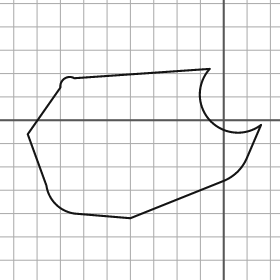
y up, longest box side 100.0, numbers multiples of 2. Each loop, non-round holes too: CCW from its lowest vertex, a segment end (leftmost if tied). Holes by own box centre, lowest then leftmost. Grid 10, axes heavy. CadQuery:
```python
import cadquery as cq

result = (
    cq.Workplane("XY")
    .moveTo(-40.0, -42.0)
    .lineTo(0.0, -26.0)
    .threePointArc((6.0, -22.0), (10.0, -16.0))
    .lineTo(16.0, -2.0)
    .threePointArc((-6.0, 0.0), (-6.0, 22.0))
    .lineTo(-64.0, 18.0)
    .threePointArc((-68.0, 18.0), (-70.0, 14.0))
    .lineTo(-84.0, -6.0)
    .lineTo(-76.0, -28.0)
    .threePointArc((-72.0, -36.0), (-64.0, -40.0))
    .close()
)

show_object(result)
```